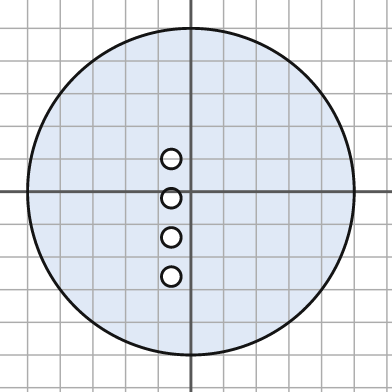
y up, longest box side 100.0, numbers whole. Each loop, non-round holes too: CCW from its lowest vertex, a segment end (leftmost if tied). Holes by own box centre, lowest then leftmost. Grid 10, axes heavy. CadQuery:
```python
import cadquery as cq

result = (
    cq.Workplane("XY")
    .moveTo(0.0, 0.0)
    .circle(50.0)
    .moveTo(-6.0, -26.0)
    .circle(3.0)
    .moveTo(-6.0, -14.0)
    .circle(3.0)
    .moveTo(-6.0, -2.0)
    .circle(3.0)
    .moveTo(-6.0, 10.0)
    .circle(3.0)
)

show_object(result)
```